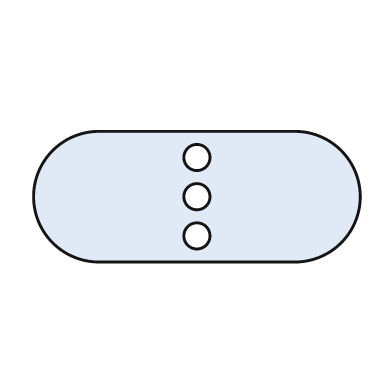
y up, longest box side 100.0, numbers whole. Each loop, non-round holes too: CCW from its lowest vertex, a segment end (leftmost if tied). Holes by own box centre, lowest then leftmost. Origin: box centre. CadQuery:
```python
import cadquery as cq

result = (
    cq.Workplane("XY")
    .moveTo(-30.0, -20.0)
    .lineTo(30.0, -20.0)
    .threePointArc((50.0, 0.0), (30.0, 20.0))
    .lineTo(-30.0, 20.0)
    .threePointArc((-50.0, 0.0), (-30.0, -20.0))
    .close()
    .moveTo(0.0, -12.0)
    .circle(4.0)
    .moveTo(0.0, 0.0)
    .circle(4.0)
    .moveTo(0.0, 12.0)
    .circle(4.0)
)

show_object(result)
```